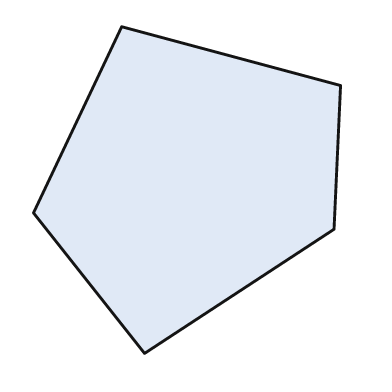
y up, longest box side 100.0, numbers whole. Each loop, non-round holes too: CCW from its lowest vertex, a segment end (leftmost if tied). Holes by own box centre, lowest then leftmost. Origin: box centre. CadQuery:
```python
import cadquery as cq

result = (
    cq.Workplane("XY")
    .moveTo(-13.0, -50.0)
    .lineTo(45.0, -12.0)
    .lineTo(47.0, 32.0)
    .lineTo(-20.0, 50.0)
    .lineTo(-47.0, -7.0)
    .close()
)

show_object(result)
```